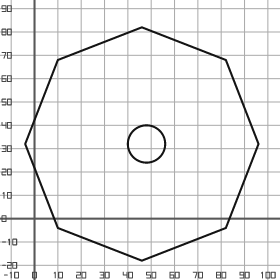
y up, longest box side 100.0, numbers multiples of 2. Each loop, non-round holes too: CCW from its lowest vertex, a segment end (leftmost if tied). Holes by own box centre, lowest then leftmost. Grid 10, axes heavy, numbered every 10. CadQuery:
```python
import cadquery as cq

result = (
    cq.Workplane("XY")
    .moveTo(46.0, -18.0)
    .lineTo(82.0, -4.0)
    .lineTo(96.0, 32.0)
    .lineTo(82.0, 68.0)
    .lineTo(46.0, 82.0)
    .lineTo(10.0, 68.0)
    .lineTo(-4.0, 32.0)
    .lineTo(10.0, -4.0)
    .close()
    .moveTo(48.0, 32.0)
    .circle(8.0)
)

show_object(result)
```